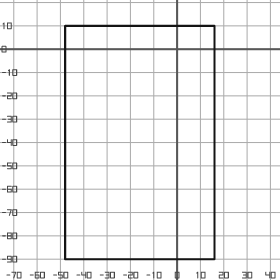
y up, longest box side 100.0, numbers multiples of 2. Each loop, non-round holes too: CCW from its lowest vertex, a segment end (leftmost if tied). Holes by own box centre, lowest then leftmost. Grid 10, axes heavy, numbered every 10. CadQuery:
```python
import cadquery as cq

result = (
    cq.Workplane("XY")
    .moveTo(-48.0, -90.0)
    .lineTo(16.0, -90.0)
    .lineTo(16.0, 10.0)
    .lineTo(-48.0, 10.0)
    .close()
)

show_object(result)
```